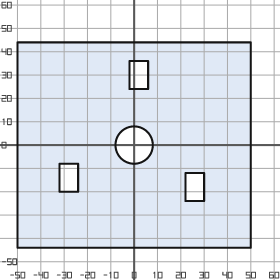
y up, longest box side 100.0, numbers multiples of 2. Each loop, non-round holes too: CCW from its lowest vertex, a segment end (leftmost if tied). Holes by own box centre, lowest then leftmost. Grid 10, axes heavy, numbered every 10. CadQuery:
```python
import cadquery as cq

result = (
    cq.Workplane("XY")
    .moveTo(-50.0, -44.0)
    .lineTo(50.0, -44.0)
    .lineTo(50.0, 44.0)
    .lineTo(-50.0, 44.0)
    .close()
    .moveTo(22.0, -24.0)
    .lineTo(30.0, -24.0)
    .lineTo(30.0, -12.0)
    .lineTo(22.0, -12.0)
    .close()
    .moveTo(-32.0, -20.0)
    .lineTo(-24.0, -20.0)
    .lineTo(-24.0, -8.0)
    .lineTo(-32.0, -8.0)
    .close()
    .moveTo(0.0, 0.0)
    .circle(8.0)
    .moveTo(-2.0, 24.0)
    .lineTo(6.0, 24.0)
    .lineTo(6.0, 36.0)
    .lineTo(-2.0, 36.0)
    .close()
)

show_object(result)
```